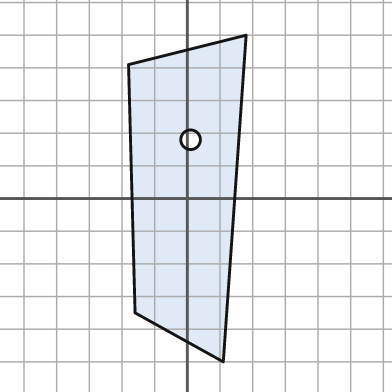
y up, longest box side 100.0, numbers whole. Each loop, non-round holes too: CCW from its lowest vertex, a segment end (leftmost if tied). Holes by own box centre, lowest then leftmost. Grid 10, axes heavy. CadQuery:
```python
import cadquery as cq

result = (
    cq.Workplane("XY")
    .moveTo(11.0, -50.0)
    .lineTo(18.0, 50.0)
    .lineTo(-18.0, 41.0)
    .lineTo(-16.0, -35.0)
    .close()
    .moveTo(1.0, 18.0)
    .circle(3.0)
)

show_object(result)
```